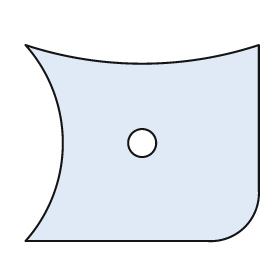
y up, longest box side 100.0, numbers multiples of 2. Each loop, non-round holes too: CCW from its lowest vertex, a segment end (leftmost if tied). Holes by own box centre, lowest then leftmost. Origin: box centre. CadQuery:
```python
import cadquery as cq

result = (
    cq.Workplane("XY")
    .moveTo(-50.0, -42.0)
    .lineTo(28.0, -42.0)
    .threePointArc((44.0, -36.0), (50.0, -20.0))
    .lineTo(50.0, 42.0)
    .threePointArc((0.0, 34.0), (-50.0, 42.0))
    .threePointArc((-34.0, 0.0), (-50.0, -42.0))
    .close()
    .moveTo(0.0, 0.0)
    .circle(6.0)
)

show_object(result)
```